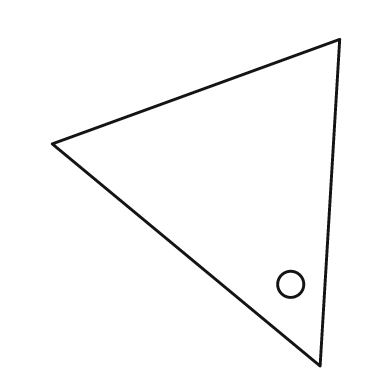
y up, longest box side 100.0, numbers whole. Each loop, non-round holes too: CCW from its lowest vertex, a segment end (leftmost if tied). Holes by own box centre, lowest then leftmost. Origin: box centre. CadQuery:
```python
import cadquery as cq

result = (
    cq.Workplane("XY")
    .moveTo(38.0, -50.0)
    .lineTo(44.0, 50.0)
    .lineTo(-44.0, 18.0)
    .close()
    .moveTo(29.0, -25.0)
    .circle(4.0)
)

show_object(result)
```